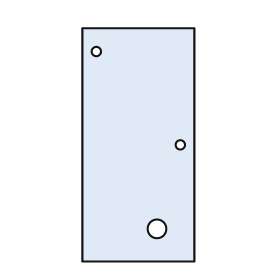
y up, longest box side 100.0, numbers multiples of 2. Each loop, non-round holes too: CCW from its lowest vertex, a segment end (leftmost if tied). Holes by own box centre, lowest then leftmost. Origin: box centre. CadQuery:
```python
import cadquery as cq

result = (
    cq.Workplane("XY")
    .moveTo(-24.0, -50.0)
    .lineTo(24.0, -50.0)
    .lineTo(24.0, 50.0)
    .lineTo(-24.0, 50.0)
    .close()
    .moveTo(8.0, -36.0)
    .circle(4.0)
    .moveTo(18.0, 0.0)
    .circle(2.0)
    .moveTo(-18.0, 40.0)
    .circle(2.0)
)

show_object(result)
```